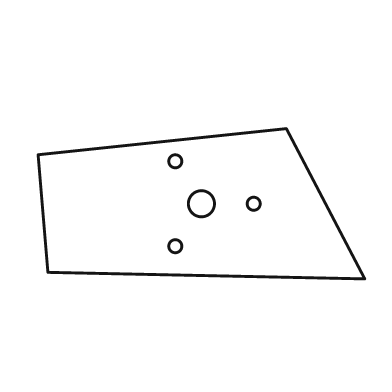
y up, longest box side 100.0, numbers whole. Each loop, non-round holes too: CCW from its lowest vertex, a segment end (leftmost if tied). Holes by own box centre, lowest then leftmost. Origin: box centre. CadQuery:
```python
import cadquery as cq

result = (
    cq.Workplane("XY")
    .moveTo(50.0, -23.0)
    .lineTo(26.0, 23.0)
    .lineTo(-50.0, 15.0)
    .lineTo(-47.0, -21.0)
    .close()
    .moveTo(-8.0, -13.0)
    .circle(2.0)
    .moveTo(0.0, 0.0)
    .circle(4.0)
    .moveTo(16.0, 0.0)
    .circle(2.0)
    .moveTo(-8.0, 13.0)
    .circle(2.0)
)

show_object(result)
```